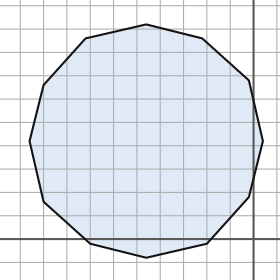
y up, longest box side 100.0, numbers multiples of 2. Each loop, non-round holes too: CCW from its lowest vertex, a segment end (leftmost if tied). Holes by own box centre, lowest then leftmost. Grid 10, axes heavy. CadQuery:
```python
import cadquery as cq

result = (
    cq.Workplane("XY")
    .moveTo(-46.0, -8.0)
    .lineTo(-20.0, -2.0)
    .lineTo(-2.0, 18.0)
    .lineTo(4.0, 42.0)
    .lineTo(-2.0, 68.0)
    .lineTo(-22.0, 86.0)
    .lineTo(-46.0, 92.0)
    .lineTo(-72.0, 86.0)
    .lineTo(-90.0, 66.0)
    .lineTo(-96.0, 42.0)
    .lineTo(-90.0, 16.0)
    .lineTo(-70.0, -2.0)
    .close()
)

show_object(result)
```